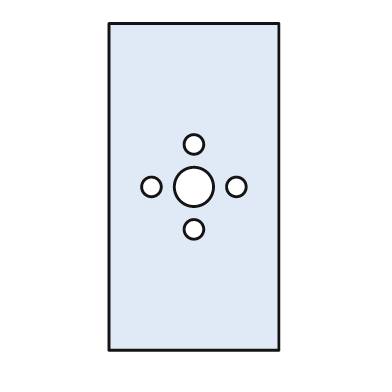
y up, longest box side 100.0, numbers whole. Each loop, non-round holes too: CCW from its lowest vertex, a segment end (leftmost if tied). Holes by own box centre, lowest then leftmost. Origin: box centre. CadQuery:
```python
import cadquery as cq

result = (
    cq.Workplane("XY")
    .moveTo(-26.0, -50.0)
    .lineTo(26.0, -50.0)
    .lineTo(26.0, 50.0)
    .lineTo(-26.0, 50.0)
    .close()
    .moveTo(0.0, -13.0)
    .circle(3.0)
    .moveTo(-13.0, 0.0)
    .circle(3.0)
    .moveTo(0.0, 0.0)
    .circle(6.0)
    .moveTo(13.0, 0.0)
    .circle(3.0)
    .moveTo(0.0, 13.0)
    .circle(3.0)
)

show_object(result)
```